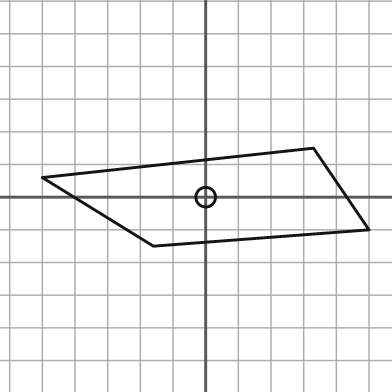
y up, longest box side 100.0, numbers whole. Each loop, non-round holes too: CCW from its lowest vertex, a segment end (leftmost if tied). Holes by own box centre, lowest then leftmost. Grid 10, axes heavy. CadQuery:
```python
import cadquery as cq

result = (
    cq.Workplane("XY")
    .moveTo(-16.0, -15.0)
    .lineTo(50.0, -10.0)
    .lineTo(33.0, 15.0)
    .lineTo(-50.0, 6.0)
    .close()
    .moveTo(0.0, 0.0)
    .circle(3.0)
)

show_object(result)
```